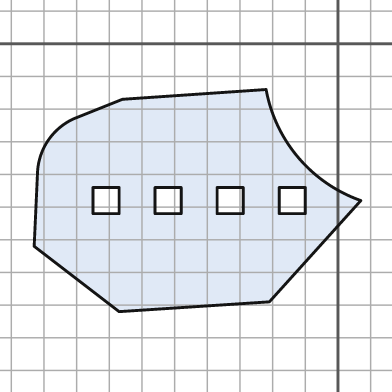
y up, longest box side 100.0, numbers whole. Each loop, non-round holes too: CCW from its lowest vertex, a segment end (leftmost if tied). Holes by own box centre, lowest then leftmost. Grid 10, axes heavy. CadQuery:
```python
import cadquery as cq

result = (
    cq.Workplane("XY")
    .moveTo(-67.0, -82.0)
    .lineTo(-21.0, -79.0)
    .lineTo(7.0, -48.0)
    .threePointArc((-12.0, -35.0), (-22.0, -14.0))
    .lineTo(-66.0, -17.0)
    .lineTo(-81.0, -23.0)
    .threePointArc((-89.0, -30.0), (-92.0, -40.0))
    .lineTo(-93.0, -62.0)
    .close()
    .moveTo(-75.0, -52.0)
    .lineTo(-67.0, -52.0)
    .lineTo(-67.0, -44.0)
    .lineTo(-75.0, -44.0)
    .close()
    .moveTo(-56.0, -52.0)
    .lineTo(-48.0, -52.0)
    .lineTo(-48.0, -44.0)
    .lineTo(-56.0, -44.0)
    .close()
    .moveTo(-37.0, -52.0)
    .lineTo(-29.0, -52.0)
    .lineTo(-29.0, -44.0)
    .lineTo(-37.0, -44.0)
    .close()
    .moveTo(-18.0, -52.0)
    .lineTo(-10.0, -52.0)
    .lineTo(-10.0, -44.0)
    .lineTo(-18.0, -44.0)
    .close()
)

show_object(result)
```